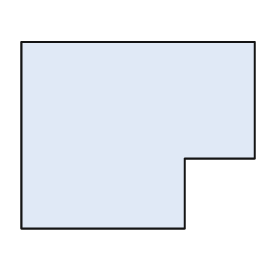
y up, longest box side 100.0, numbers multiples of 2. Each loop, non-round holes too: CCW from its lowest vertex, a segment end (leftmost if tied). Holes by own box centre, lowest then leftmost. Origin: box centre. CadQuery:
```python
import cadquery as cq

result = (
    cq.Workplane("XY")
    .moveTo(-50.0, -40.0)
    .lineTo(20.0, -40.0)
    .lineTo(20.0, -10.0)
    .lineTo(50.0, -10.0)
    .lineTo(50.0, 40.0)
    .lineTo(-50.0, 40.0)
    .close()
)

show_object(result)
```